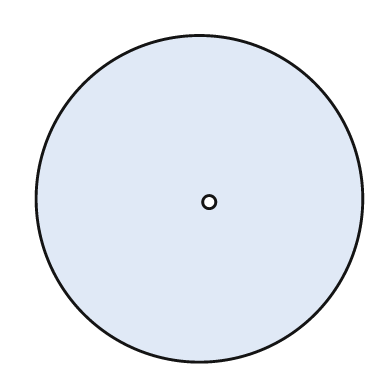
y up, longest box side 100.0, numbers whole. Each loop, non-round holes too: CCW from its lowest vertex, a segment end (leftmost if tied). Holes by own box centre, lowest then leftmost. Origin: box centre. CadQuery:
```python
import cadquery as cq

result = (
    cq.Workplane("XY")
    .moveTo(0.0, 0.0)
    .circle(50.0)
    .moveTo(3.0, -1.0)
    .circle(2.0)
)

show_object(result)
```